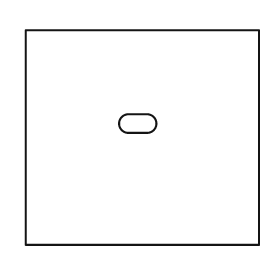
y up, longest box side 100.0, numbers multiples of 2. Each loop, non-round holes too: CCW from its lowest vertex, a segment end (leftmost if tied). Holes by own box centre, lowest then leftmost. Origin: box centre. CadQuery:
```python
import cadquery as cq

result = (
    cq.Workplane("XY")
    .moveTo(-50.0, -46.0)
    .lineTo(50.0, -46.0)
    .lineTo(50.0, 46.0)
    .lineTo(-50.0, 46.0)
    .close()
    .moveTo(-6.0, 2.0)
    .lineTo(2.0, 2.0)
    .threePointArc((6.0, 6.0), (2.0, 10.0))
    .lineTo(-6.0, 10.0)
    .threePointArc((-10.0, 6.0), (-6.0, 2.0))
    .close()
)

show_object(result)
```